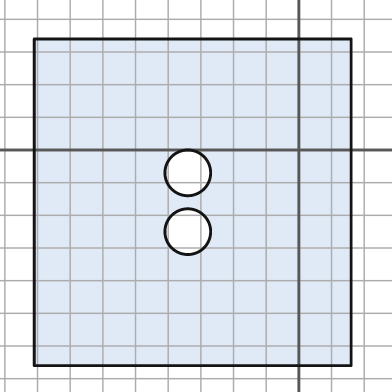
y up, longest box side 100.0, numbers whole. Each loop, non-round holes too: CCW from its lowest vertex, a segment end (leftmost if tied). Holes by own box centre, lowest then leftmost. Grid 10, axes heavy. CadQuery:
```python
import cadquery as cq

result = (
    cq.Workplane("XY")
    .moveTo(-81.0, -66.0)
    .lineTo(16.0, -66.0)
    .lineTo(16.0, 34.0)
    .lineTo(-81.0, 34.0)
    .close()
    .moveTo(-34.0, -25.0)
    .circle(7.0)
    .moveTo(-34.0, -7.0)
    .circle(7.0)
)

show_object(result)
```